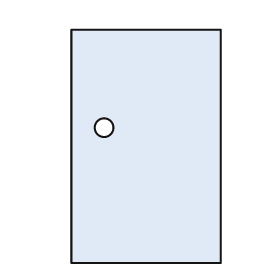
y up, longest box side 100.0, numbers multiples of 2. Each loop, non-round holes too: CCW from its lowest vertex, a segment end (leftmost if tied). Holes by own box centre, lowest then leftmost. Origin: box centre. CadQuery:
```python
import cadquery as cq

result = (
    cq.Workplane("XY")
    .moveTo(-32.0, -50.0)
    .lineTo(32.0, -50.0)
    .lineTo(32.0, 50.0)
    .lineTo(-32.0, 50.0)
    .close()
    .moveTo(-18.0, 8.0)
    .circle(4.0)
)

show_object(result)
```